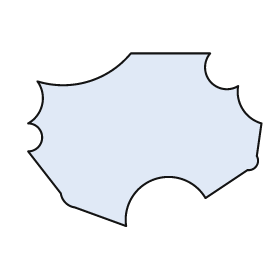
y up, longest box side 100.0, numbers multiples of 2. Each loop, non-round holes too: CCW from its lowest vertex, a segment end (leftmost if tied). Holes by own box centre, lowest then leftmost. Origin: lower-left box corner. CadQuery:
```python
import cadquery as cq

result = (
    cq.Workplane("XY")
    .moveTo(42.0, 0.0)
    .threePointArc((54.0, 20.0), (76.0, 12.0))
    .lineTo(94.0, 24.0)
    .threePointArc((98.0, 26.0), (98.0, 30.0))
    .lineTo(100.0, 44.0)
    .threePointArc((92.0, 50.0), (90.0, 60.0))
    .threePointArc((78.0, 62.0), (78.0, 74.0))
    .lineTo(44.0, 74.0)
    .threePointArc((26.0, 62.0), (4.0, 62.0))
    .threePointArc((6.0, 52.0), (0.0, 44.0))
    .threePointArc((6.0, 38.0), (0.0, 32.0))
    .lineTo(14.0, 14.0)
    .threePointArc((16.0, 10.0), (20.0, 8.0))
    .close()
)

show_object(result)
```